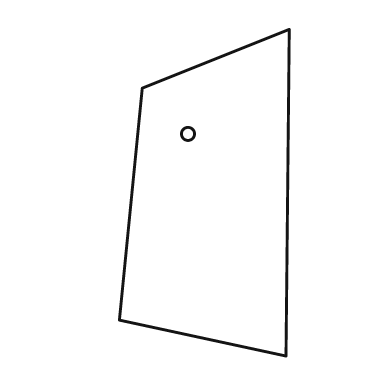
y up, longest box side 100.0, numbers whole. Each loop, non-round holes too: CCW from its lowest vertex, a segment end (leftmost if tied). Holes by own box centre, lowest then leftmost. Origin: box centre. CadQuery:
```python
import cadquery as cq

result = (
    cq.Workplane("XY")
    .moveTo(25.0, -50.0)
    .lineTo(26.0, 50.0)
    .lineTo(-19.0, 32.0)
    .lineTo(-26.0, -39.0)
    .close()
    .moveTo(-5.0, 18.0)
    .circle(2.0)
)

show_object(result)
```